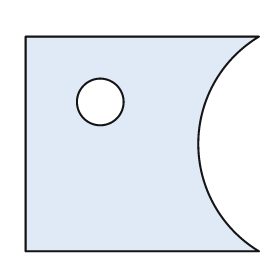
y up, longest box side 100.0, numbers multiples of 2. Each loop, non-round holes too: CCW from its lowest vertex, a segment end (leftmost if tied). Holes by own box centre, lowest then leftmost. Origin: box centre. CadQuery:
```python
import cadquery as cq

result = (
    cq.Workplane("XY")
    .moveTo(-50.0, -46.0)
    .lineTo(50.0, -46.0)
    .threePointArc((24.0, 0.0), (50.0, 46.0))
    .lineTo(-50.0, 46.0)
    .close()
    .moveTo(-18.0, 18.0)
    .circle(10.0)
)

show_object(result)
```